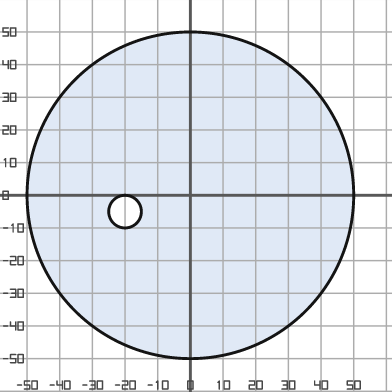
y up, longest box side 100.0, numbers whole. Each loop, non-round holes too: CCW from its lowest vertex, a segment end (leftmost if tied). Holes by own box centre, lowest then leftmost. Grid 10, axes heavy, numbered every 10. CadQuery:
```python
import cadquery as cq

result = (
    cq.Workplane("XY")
    .moveTo(0.0, 0.0)
    .circle(50.0)
    .moveTo(-20.0, -5.0)
    .circle(5.0)
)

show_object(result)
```